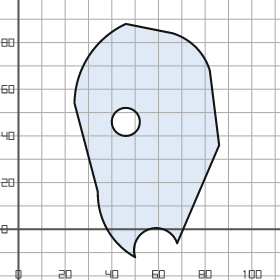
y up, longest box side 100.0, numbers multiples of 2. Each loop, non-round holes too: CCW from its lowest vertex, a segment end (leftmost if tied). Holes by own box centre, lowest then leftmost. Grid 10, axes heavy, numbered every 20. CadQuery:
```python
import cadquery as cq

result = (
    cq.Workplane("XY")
    .moveTo(50.0, -12.0)
    .threePointArc((56.0, 0.0), (68.0, -6.0))
    .lineTo(86.0, 36.0)
    .lineTo(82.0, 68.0)
    .threePointArc((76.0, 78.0), (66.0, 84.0))
    .lineTo(46.0, 88.0)
    .threePointArc((30.0, 74.0), (24.0, 54.0))
    .lineTo(34.0, 16.0)
    .threePointArc((38.0, 0.0), (50.0, -12.0))
    .close()
    .moveTo(46.0, 46.0)
    .circle(6.0)
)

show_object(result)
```